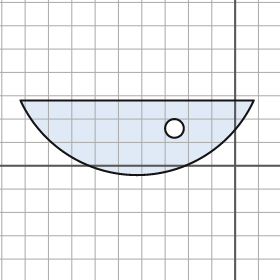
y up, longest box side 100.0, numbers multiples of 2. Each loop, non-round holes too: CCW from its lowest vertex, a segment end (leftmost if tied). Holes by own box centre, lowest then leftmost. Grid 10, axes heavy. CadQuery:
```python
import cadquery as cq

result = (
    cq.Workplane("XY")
    .moveTo(-92.0, 28.0)
    .threePointArc((-42.0, -4.0), (8.0, 28.0))
    .close()
    .moveTo(-26.0, 16.0)
    .circle(4.0)
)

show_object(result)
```